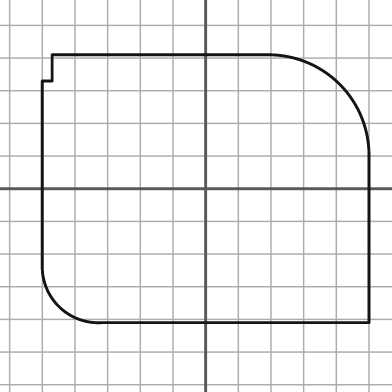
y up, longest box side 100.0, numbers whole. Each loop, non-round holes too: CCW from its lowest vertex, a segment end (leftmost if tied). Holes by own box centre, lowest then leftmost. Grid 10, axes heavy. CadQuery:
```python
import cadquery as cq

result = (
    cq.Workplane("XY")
    .moveTo(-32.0, -41.0)
    .lineTo(50.0, -41.0)
    .lineTo(50.0, 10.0)
    .threePointArc((41.0, 32.0), (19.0, 41.0))
    .lineTo(-47.0, 41.0)
    .lineTo(-47.0, 33.0)
    .lineTo(-50.0, 33.0)
    .lineTo(-50.0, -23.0)
    .threePointArc((-45.0, -36.0), (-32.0, -41.0))
    .close()
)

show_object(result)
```